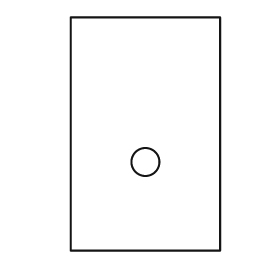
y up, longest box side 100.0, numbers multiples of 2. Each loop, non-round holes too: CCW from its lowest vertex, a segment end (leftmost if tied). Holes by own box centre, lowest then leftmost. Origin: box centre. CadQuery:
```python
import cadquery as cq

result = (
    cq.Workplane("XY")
    .moveTo(-32.0, -50.0)
    .lineTo(32.0, -50.0)
    .lineTo(32.0, 50.0)
    .lineTo(-32.0, 50.0)
    .close()
    .moveTo(0.0, -12.0)
    .circle(6.0)
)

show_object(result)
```